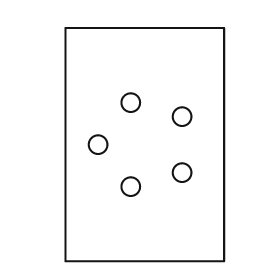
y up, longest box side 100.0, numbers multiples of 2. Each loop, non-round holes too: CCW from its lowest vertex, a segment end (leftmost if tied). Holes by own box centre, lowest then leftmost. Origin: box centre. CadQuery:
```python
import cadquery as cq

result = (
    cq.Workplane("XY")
    .moveTo(-34.0, -50.0)
    .lineTo(34.0, -50.0)
    .lineTo(34.0, 50.0)
    .lineTo(-34.0, 50.0)
    .close()
    .moveTo(-6.0, -18.0)
    .circle(4.0)
    .moveTo(16.0, -12.0)
    .circle(4.0)
    .moveTo(-20.0, 0.0)
    .circle(4.0)
    .moveTo(16.0, 12.0)
    .circle(4.0)
    .moveTo(-6.0, 18.0)
    .circle(4.0)
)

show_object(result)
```